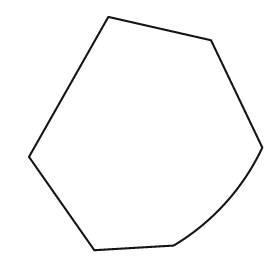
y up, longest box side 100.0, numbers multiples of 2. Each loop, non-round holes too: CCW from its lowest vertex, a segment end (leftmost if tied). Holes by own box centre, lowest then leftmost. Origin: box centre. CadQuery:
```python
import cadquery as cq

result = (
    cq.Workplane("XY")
    .moveTo(-22.0, -50.0)
    .lineTo(12.0, -48.0)
    .threePointArc((34.0, -30.0), (50.0, -6.0))
    .lineTo(28.0, 40.0)
    .lineTo(-16.0, 50.0)
    .lineTo(-50.0, -10.0)
    .close()
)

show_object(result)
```